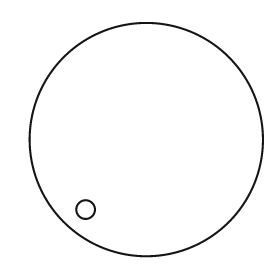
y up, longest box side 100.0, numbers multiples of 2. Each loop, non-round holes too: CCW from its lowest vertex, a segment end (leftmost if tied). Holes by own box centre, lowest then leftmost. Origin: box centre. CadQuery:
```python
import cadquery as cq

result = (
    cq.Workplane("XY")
    .moveTo(0.0, 0.0)
    .circle(50.0)
    .moveTo(-26.0, -30.0)
    .circle(4.0)
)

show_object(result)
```